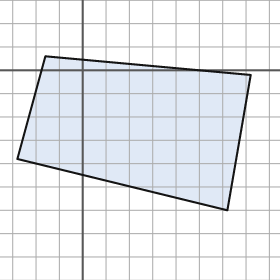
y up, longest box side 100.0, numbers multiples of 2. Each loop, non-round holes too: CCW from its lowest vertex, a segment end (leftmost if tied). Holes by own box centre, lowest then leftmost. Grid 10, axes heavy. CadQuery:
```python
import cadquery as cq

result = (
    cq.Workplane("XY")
    .moveTo(62.0, -60.0)
    .lineTo(72.0, -2.0)
    .lineTo(-16.0, 6.0)
    .lineTo(-28.0, -38.0)
    .close()
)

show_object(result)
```